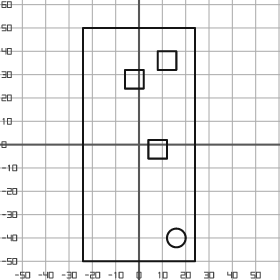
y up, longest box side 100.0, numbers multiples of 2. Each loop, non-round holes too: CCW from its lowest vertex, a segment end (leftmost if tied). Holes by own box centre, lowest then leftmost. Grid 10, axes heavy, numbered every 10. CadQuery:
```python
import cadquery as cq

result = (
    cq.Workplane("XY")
    .moveTo(-24.0, -50.0)
    .lineTo(24.0, -50.0)
    .lineTo(24.0, 50.0)
    .lineTo(-24.0, 50.0)
    .close()
    .moveTo(16.0, -40.0)
    .circle(4.0)
    .moveTo(4.0, -6.0)
    .lineTo(12.0, -6.0)
    .lineTo(12.0, 2.0)
    .lineTo(4.0, 2.0)
    .close()
    .moveTo(-6.0, 24.0)
    .lineTo(2.0, 24.0)
    .lineTo(2.0, 32.0)
    .lineTo(-6.0, 32.0)
    .close()
    .moveTo(8.0, 32.0)
    .lineTo(16.0, 32.0)
    .lineTo(16.0, 40.0)
    .lineTo(8.0, 40.0)
    .close()
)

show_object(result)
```